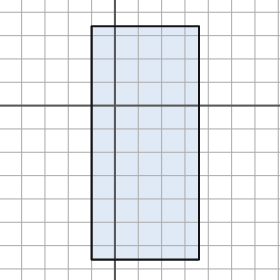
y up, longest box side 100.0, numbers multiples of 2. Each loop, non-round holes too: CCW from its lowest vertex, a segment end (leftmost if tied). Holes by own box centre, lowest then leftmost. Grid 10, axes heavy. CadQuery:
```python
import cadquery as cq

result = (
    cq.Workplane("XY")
    .moveTo(-10.0, -66.0)
    .lineTo(36.0, -66.0)
    .lineTo(36.0, 34.0)
    .lineTo(-10.0, 34.0)
    .close()
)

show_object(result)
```